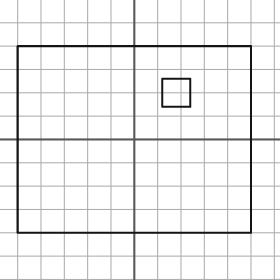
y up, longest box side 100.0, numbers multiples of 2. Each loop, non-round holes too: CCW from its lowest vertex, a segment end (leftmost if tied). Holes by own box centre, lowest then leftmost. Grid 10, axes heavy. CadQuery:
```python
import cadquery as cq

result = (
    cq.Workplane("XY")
    .moveTo(-50.0, -40.0)
    .lineTo(50.0, -40.0)
    .lineTo(50.0, 40.0)
    .lineTo(-50.0, 40.0)
    .close()
    .moveTo(12.0, 14.0)
    .lineTo(24.0, 14.0)
    .lineTo(24.0, 26.0)
    .lineTo(12.0, 26.0)
    .close()
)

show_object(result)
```